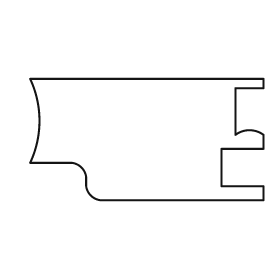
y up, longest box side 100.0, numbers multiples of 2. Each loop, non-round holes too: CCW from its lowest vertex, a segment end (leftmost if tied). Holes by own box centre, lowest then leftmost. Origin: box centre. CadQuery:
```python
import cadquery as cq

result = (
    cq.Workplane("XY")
    .moveTo(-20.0, -26.0)
    .lineTo(50.0, -26.0)
    .lineTo(50.0, -20.0)
    .lineTo(32.0, -20.0)
    .lineTo(32.0, -4.0)
    .lineTo(50.0, -4.0)
    .lineTo(50.0, 2.0)
    .threePointArc((44.0, 4.0), (38.0, 2.0))
    .lineTo(38.0, 22.0)
    .lineTo(50.0, 22.0)
    .lineTo(50.0, 26.0)
    .lineTo(-50.0, 26.0)
    .threePointArc((-46.0, 8.0), (-50.0, -10.0))
    .lineTo(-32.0, -10.0)
    .threePointArc((-28.0, -12.0), (-26.0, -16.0))
    .lineTo(-26.0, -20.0)
    .threePointArc((-24.0, -24.0), (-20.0, -26.0))
    .close()
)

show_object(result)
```